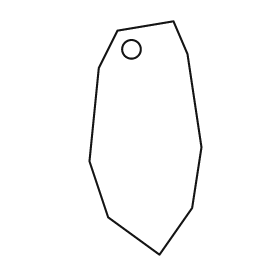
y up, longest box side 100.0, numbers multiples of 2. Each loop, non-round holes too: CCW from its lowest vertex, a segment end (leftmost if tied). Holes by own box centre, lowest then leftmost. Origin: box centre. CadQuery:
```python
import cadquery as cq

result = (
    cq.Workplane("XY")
    .moveTo(6.0, -50.0)
    .lineTo(20.0, -30.0)
    .lineTo(24.0, -4.0)
    .lineTo(18.0, 36.0)
    .lineTo(12.0, 50.0)
    .lineTo(-12.0, 46.0)
    .lineTo(-20.0, 30.0)
    .lineTo(-24.0, -10.0)
    .lineTo(-16.0, -34.0)
    .close()
    .moveTo(-6.0, 38.0)
    .circle(4.0)
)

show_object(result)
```